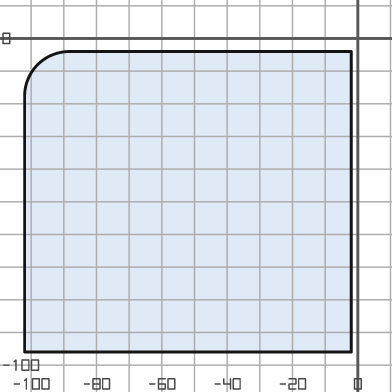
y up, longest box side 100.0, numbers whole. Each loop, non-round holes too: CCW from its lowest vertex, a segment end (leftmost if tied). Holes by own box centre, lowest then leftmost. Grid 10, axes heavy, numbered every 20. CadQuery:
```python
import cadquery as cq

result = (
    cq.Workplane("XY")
    .moveTo(-102.0, -96.0)
    .lineTo(-2.0, -96.0)
    .lineTo(-2.0, -4.0)
    .lineTo(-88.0, -4.0)
    .threePointArc((-98.0, -8.0), (-102.0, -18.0))
    .close()
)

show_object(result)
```